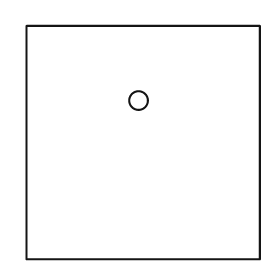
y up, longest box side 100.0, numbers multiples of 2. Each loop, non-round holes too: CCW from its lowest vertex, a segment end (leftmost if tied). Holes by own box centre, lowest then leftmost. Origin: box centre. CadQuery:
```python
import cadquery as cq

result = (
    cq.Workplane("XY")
    .moveTo(-50.0, -50.0)
    .lineTo(50.0, -50.0)
    .lineTo(50.0, 50.0)
    .lineTo(-50.0, 50.0)
    .close()
    .moveTo(-2.0, 18.0)
    .circle(4.0)
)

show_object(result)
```